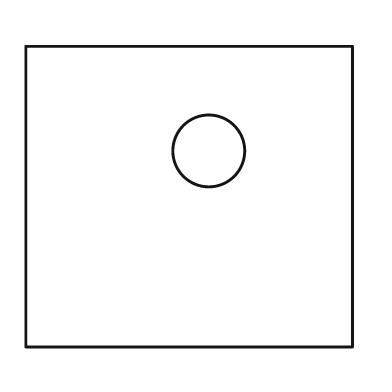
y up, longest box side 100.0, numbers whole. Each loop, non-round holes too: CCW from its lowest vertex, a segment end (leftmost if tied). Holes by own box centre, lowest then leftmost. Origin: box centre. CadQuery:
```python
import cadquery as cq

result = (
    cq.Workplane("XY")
    .moveTo(-50.0, -46.0)
    .lineTo(50.0, -46.0)
    .lineTo(50.0, 46.0)
    .lineTo(-50.0, 46.0)
    .close()
    .moveTo(6.0, 14.0)
    .circle(11.0)
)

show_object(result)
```